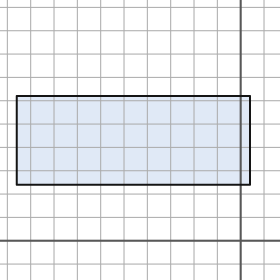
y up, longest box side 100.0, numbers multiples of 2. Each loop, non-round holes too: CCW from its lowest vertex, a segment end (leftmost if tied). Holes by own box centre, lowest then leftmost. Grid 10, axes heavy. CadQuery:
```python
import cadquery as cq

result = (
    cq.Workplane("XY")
    .moveTo(-96.0, 24.0)
    .lineTo(4.0, 24.0)
    .lineTo(4.0, 62.0)
    .lineTo(-96.0, 62.0)
    .close()
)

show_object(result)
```